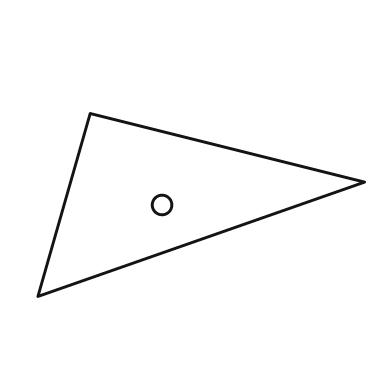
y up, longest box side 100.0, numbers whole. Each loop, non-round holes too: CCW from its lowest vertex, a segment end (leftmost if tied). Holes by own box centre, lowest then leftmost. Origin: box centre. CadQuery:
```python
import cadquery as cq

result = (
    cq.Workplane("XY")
    .moveTo(-50.0, -28.0)
    .lineTo(50.0, 7.0)
    .lineTo(-34.0, 28.0)
    .close()
    .moveTo(-12.0, 0.0)
    .circle(3.0)
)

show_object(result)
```